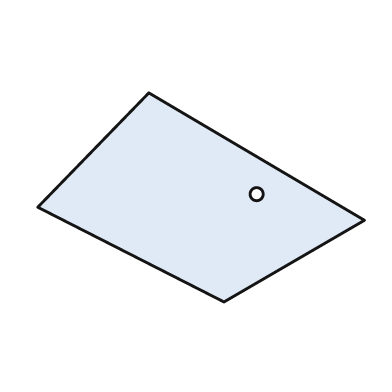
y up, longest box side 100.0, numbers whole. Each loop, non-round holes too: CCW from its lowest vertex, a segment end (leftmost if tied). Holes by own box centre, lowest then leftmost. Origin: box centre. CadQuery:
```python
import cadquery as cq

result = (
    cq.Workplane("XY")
    .moveTo(7.0, -32.0)
    .lineTo(50.0, -7.0)
    .lineTo(-16.0, 32.0)
    .lineTo(-50.0, -3.0)
    .close()
    .moveTo(17.0, 1.0)
    .circle(2.0)
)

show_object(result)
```